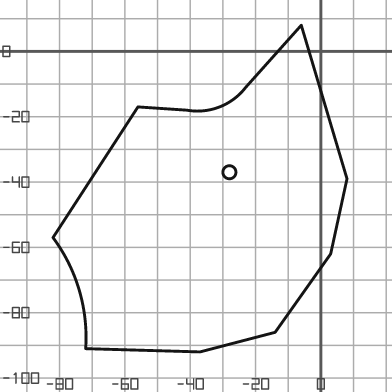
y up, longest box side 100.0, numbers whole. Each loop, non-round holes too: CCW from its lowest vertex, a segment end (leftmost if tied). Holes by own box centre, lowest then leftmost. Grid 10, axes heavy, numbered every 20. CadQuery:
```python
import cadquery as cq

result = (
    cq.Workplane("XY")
    .moveTo(-37.0, -92.0)
    .lineTo(-14.0, -86.0)
    .lineTo(3.0, -62.0)
    .lineTo(8.0, -39.0)
    .lineTo(-6.0, 8.0)
    .lineTo(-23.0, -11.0)
    .threePointArc((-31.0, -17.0), (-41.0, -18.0))
    .lineTo(-56.0, -17.0)
    .lineTo(-82.0, -57.0)
    .threePointArc((-74.0, -73.0), (-72.0, -91.0))
    .close()
    .moveTo(-28.0, -37.0)
    .circle(2.0)
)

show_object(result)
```